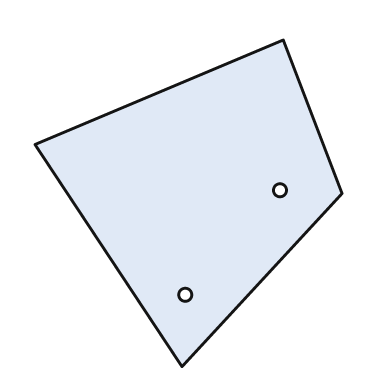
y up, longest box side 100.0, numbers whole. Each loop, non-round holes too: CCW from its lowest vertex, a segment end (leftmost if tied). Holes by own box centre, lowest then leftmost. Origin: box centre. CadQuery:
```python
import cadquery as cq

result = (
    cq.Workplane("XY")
    .moveTo(-2.0, -50.0)
    .lineTo(47.0, 3.0)
    .lineTo(29.0, 50.0)
    .lineTo(-47.0, 18.0)
    .close()
    .moveTo(-1.0, -28.0)
    .circle(2.0)
    .moveTo(28.0, 4.0)
    .circle(2.0)
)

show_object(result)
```